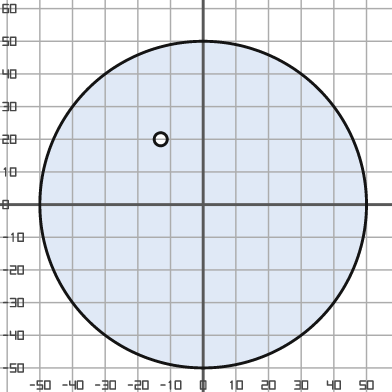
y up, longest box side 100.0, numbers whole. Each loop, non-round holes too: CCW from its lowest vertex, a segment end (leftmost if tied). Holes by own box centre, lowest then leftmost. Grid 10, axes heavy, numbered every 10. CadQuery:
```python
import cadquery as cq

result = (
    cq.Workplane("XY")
    .moveTo(0.0, 0.0)
    .circle(50.0)
    .moveTo(-13.0, 20.0)
    .circle(2.0)
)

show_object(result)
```